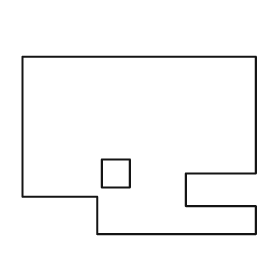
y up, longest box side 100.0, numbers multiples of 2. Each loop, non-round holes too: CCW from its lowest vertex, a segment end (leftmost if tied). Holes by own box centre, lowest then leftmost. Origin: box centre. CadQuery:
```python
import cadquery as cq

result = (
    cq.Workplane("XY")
    .moveTo(-18.0, -38.0)
    .lineTo(50.0, -38.0)
    .lineTo(50.0, -26.0)
    .lineTo(20.0, -26.0)
    .lineTo(20.0, -12.0)
    .lineTo(50.0, -12.0)
    .lineTo(50.0, 38.0)
    .lineTo(-50.0, 38.0)
    .lineTo(-50.0, -22.0)
    .lineTo(-18.0, -22.0)
    .close()
    .moveTo(-16.0, -18.0)
    .lineTo(-4.0, -18.0)
    .lineTo(-4.0, -6.0)
    .lineTo(-16.0, -6.0)
    .close()
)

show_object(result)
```